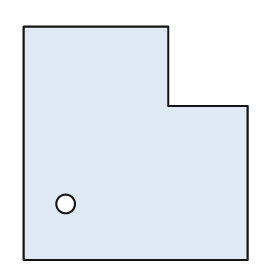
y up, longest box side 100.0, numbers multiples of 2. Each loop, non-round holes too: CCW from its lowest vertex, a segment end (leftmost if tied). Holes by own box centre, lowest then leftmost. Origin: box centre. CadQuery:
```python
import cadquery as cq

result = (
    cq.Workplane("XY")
    .moveTo(-48.0, -50.0)
    .lineTo(48.0, -50.0)
    .lineTo(48.0, 16.0)
    .lineTo(14.0, 16.0)
    .lineTo(14.0, 50.0)
    .lineTo(-48.0, 50.0)
    .close()
    .moveTo(-30.0, -26.0)
    .circle(4.0)
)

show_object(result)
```